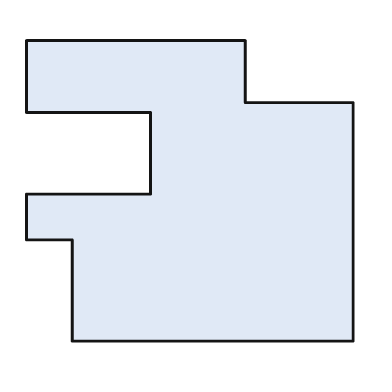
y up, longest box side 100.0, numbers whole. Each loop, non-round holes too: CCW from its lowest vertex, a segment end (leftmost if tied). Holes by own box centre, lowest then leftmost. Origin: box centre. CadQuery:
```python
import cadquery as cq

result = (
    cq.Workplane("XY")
    .moveTo(-36.0, -46.0)
    .lineTo(50.0, -46.0)
    .lineTo(50.0, 27.0)
    .lineTo(17.0, 27.0)
    .lineTo(17.0, 46.0)
    .lineTo(-50.0, 46.0)
    .lineTo(-50.0, 24.0)
    .lineTo(-12.0, 24.0)
    .lineTo(-12.0, -1.0)
    .lineTo(-50.0, -1.0)
    .lineTo(-50.0, -15.0)
    .lineTo(-36.0, -15.0)
    .close()
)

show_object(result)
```